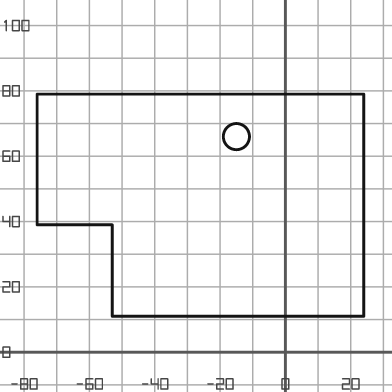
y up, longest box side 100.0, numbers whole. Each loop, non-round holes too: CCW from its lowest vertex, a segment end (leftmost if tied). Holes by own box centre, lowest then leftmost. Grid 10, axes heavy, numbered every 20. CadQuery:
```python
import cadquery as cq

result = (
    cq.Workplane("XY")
    .moveTo(-53.0, 11.0)
    .lineTo(24.0, 11.0)
    .lineTo(24.0, 79.0)
    .lineTo(-76.0, 79.0)
    .lineTo(-76.0, 39.0)
    .lineTo(-53.0, 39.0)
    .close()
    .moveTo(-15.0, 66.0)
    .circle(4.0)
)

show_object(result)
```